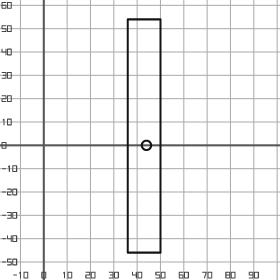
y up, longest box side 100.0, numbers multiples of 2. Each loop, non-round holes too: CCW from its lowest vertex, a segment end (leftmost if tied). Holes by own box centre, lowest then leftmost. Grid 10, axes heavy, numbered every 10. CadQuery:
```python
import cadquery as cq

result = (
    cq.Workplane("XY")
    .moveTo(36.0, -46.0)
    .lineTo(50.0, -46.0)
    .lineTo(50.0, 54.0)
    .lineTo(36.0, 54.0)
    .close()
    .moveTo(44.0, 0.0)
    .circle(2.0)
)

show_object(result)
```